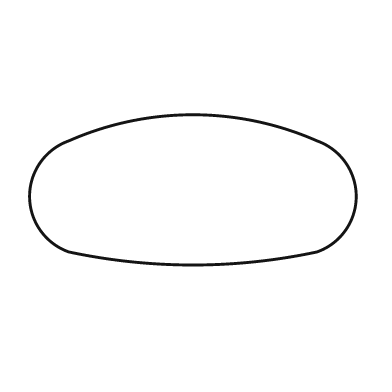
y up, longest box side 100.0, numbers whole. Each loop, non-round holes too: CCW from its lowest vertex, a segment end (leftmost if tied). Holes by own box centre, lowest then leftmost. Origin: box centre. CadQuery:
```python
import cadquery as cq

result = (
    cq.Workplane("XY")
    .moveTo(-38.0, -19.0)
    .threePointArc((0.0, -23.0), (38.0, -19.0))
    .threePointArc((50.0, -2.0), (38.0, 15.0))
    .threePointArc((0.0, 23.0), (-38.0, 15.0))
    .threePointArc((-50.0, -2.0), (-38.0, -19.0))
    .close()
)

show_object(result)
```